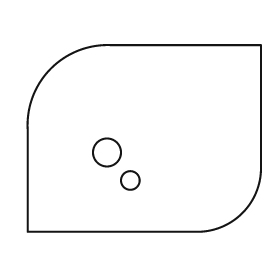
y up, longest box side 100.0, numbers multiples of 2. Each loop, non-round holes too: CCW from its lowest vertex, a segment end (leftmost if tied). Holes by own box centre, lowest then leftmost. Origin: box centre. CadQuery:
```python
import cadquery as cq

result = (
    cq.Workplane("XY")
    .moveTo(-50.0, -40.0)
    .lineTo(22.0, -40.0)
    .threePointArc((42.0, -32.0), (50.0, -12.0))
    .lineTo(50.0, 40.0)
    .lineTo(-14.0, 40.0)
    .threePointArc((-40.0, 30.0), (-50.0, 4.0))
    .close()
    .moveTo(-6.0, -18.0)
    .circle(4.0)
    .moveTo(-16.0, -6.0)
    .circle(6.0)
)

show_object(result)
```